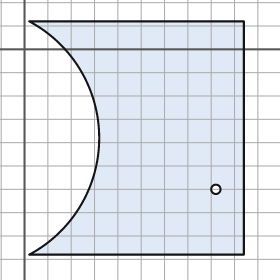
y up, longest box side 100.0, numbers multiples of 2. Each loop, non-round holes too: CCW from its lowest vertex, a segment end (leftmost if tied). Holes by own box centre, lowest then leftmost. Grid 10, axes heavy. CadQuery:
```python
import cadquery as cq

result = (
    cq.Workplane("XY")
    .moveTo(2.0, -88.0)
    .lineTo(94.0, -88.0)
    .lineTo(94.0, 12.0)
    .lineTo(2.0, 12.0)
    .threePointArc((32.0, -38.0), (2.0, -88.0))
    .close()
    .moveTo(82.0, -60.0)
    .circle(2.0)
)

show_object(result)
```